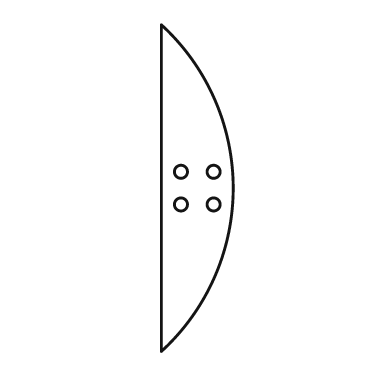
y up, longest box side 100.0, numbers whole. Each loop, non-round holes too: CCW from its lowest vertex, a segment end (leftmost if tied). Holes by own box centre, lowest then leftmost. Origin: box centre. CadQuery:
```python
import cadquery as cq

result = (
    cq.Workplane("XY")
    .moveTo(-11.0, -50.0)
    .threePointArc((11.0, 0.0), (-11.0, 50.0))
    .close()
    .moveTo(-5.0, -5.0)
    .circle(2.0)
    .moveTo(5.0, -5.0)
    .circle(2.0)
    .moveTo(-5.0, 5.0)
    .circle(2.0)
    .moveTo(5.0, 5.0)
    .circle(2.0)
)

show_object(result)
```